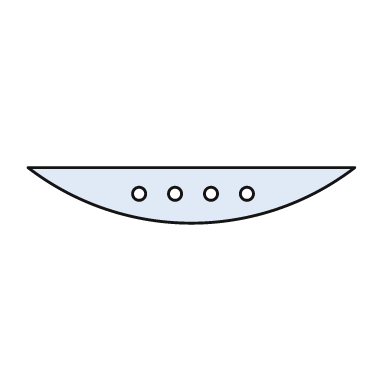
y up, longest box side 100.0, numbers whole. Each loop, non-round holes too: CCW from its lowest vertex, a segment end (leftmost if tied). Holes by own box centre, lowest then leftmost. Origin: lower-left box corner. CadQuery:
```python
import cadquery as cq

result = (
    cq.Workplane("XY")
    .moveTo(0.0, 17.0)
    .threePointArc((50.0, 0.0), (100.0, 17.0))
    .close()
    .moveTo(34.0, 9.0)
    .circle(2.0)
    .moveTo(45.0, 9.0)
    .circle(2.0)
    .moveTo(56.0, 9.0)
    .circle(2.0)
    .moveTo(67.0, 9.0)
    .circle(2.0)
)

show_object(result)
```